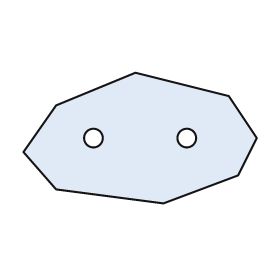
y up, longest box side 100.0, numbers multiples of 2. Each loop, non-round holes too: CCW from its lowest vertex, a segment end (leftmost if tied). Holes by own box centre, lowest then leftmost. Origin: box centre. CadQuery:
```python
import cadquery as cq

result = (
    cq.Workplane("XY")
    .moveTo(10.0, -28.0)
    .lineTo(42.0, -16.0)
    .lineTo(50.0, 0.0)
    .lineTo(38.0, 18.0)
    .lineTo(-2.0, 28.0)
    .lineTo(-36.0, 14.0)
    .lineTo(-50.0, -6.0)
    .lineTo(-36.0, -22.0)
    .close()
    .moveTo(-20.0, 0.0)
    .circle(4.0)
    .moveTo(20.0, 0.0)
    .circle(4.0)
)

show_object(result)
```